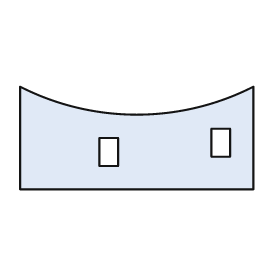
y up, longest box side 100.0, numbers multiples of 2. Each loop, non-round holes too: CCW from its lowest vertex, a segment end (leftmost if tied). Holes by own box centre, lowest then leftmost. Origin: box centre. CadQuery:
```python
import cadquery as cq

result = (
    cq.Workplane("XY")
    .moveTo(-50.0, -22.0)
    .lineTo(50.0, -22.0)
    .lineTo(50.0, 22.0)
    .threePointArc((0.0, 10.0), (-50.0, 22.0))
    .close()
    .moveTo(-16.0, -12.0)
    .lineTo(-8.0, -12.0)
    .lineTo(-8.0, 0.0)
    .lineTo(-16.0, 0.0)
    .close()
    .moveTo(32.0, -8.0)
    .lineTo(40.0, -8.0)
    .lineTo(40.0, 4.0)
    .lineTo(32.0, 4.0)
    .close()
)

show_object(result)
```